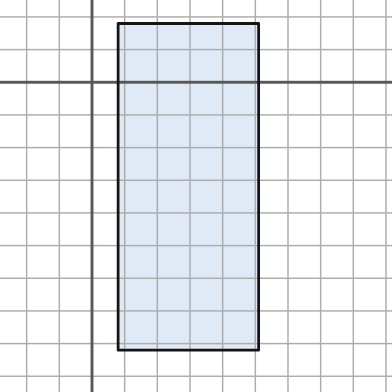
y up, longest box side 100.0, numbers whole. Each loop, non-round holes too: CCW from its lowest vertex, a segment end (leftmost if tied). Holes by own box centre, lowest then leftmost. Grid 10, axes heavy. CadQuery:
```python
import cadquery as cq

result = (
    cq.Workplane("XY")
    .moveTo(8.0, -82.0)
    .lineTo(51.0, -82.0)
    .lineTo(51.0, 18.0)
    .lineTo(8.0, 18.0)
    .close()
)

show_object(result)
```